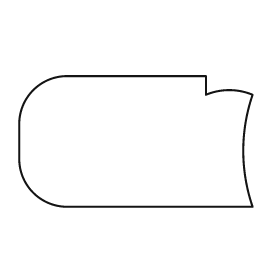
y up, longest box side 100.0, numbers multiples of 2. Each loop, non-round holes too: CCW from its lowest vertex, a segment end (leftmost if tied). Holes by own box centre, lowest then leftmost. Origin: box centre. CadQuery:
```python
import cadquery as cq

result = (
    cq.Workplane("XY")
    .moveTo(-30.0, -28.0)
    .lineTo(50.0, -28.0)
    .threePointArc((46.0, -4.0), (50.0, 20.0))
    .threePointArc((40.0, 22.0), (30.0, 20.0))
    .lineTo(30.0, 28.0)
    .lineTo(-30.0, 28.0)
    .threePointArc((-44.0, 22.0), (-50.0, 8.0))
    .lineTo(-50.0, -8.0)
    .threePointArc((-44.0, -22.0), (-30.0, -28.0))
    .close()
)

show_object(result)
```